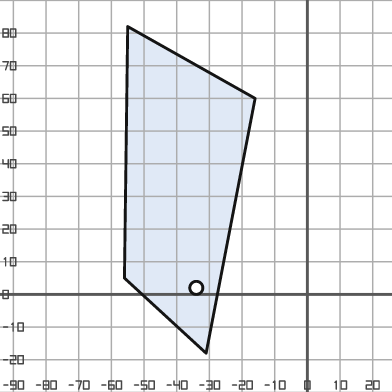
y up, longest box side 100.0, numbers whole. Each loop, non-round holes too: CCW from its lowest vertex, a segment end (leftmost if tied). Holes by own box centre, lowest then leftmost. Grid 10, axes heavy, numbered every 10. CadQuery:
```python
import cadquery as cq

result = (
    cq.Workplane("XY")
    .moveTo(-31.0, -18.0)
    .lineTo(-16.0, 60.0)
    .lineTo(-55.0, 82.0)
    .lineTo(-56.0, 5.0)
    .close()
    .moveTo(-34.0, 2.0)
    .circle(2.0)
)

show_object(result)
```